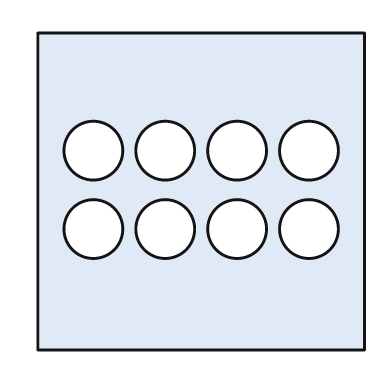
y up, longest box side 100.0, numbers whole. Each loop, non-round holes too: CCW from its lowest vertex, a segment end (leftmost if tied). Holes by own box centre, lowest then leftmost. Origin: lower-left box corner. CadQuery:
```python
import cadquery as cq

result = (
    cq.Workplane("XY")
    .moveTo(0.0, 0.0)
    .lineTo(100.0, 0.0)
    .lineTo(100.0, 97.0)
    .lineTo(0.0, 97.0)
    .close()
    .moveTo(17.0, 37.0)
    .circle(9.0)
    .moveTo(39.0, 37.0)
    .circle(9.0)
    .moveTo(61.0, 37.0)
    .circle(9.0)
    .moveTo(83.0, 37.0)
    .circle(9.0)
    .moveTo(17.0, 61.0)
    .circle(9.0)
    .moveTo(39.0, 61.0)
    .circle(9.0)
    .moveTo(61.0, 61.0)
    .circle(9.0)
    .moveTo(83.0, 61.0)
    .circle(9.0)
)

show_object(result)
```